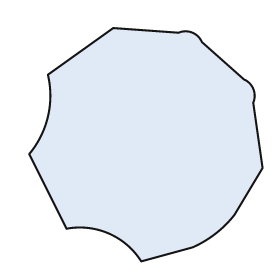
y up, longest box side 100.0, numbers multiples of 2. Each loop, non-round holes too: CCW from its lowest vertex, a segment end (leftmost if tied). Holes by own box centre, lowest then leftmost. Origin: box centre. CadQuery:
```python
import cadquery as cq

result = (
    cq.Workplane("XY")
    .moveTo(-2.0, -50.0)
    .lineTo(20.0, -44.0)
    .threePointArc((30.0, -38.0), (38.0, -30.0))
    .lineTo(50.0, -10.0)
    .lineTo(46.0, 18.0)
    .threePointArc((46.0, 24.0), (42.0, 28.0))
    .lineTo(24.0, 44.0)
    .threePointArc((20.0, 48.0), (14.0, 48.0))
    .lineTo(-14.0, 50.0)
    .lineTo(-42.0, 30.0)
    .threePointArc((-42.0, 12.0), (-50.0, -4.0))
    .lineTo(-34.0, -36.0)
    .threePointArc((-16.0, -38.0), (-2.0, -50.0))
    .close()
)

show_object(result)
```